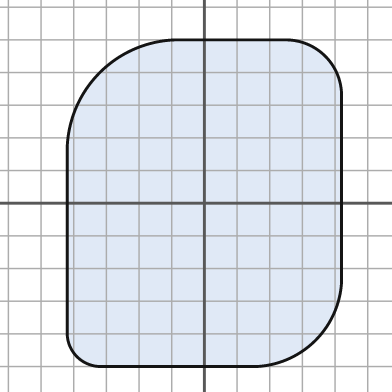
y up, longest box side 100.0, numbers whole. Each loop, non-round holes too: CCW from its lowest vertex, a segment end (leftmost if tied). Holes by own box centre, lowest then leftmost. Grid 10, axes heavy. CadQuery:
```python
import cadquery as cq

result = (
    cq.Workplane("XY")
    .moveTo(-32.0, -50.0)
    .lineTo(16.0, -50.0)
    .threePointArc((34.0, -42.0), (42.0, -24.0))
    .lineTo(42.0, 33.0)
    .threePointArc((37.0, 45.0), (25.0, 50.0))
    .lineTo(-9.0, 50.0)
    .threePointArc((-32.0, 40.0), (-42.0, 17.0))
    .lineTo(-42.0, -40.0)
    .threePointArc((-39.0, -47.0), (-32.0, -50.0))
    .close()
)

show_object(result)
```